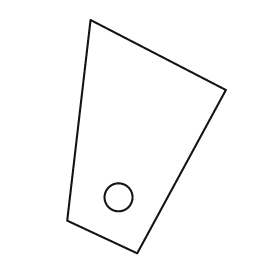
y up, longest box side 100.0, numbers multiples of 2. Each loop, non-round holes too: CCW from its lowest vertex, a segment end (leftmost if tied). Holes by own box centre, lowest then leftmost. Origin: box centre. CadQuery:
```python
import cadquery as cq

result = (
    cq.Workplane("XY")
    .moveTo(-4.0, -50.0)
    .lineTo(34.0, 20.0)
    .lineTo(-24.0, 50.0)
    .lineTo(-34.0, -36.0)
    .close()
    .moveTo(-12.0, -26.0)
    .circle(6.0)
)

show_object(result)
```